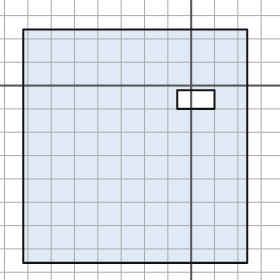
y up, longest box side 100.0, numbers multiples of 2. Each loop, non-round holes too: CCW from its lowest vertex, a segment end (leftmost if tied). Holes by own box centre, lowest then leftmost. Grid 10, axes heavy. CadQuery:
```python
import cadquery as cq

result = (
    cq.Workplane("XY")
    .moveTo(-72.0, -76.0)
    .lineTo(24.0, -76.0)
    .lineTo(24.0, 24.0)
    .lineTo(-72.0, 24.0)
    .close()
    .moveTo(-6.0, -10.0)
    .lineTo(10.0, -10.0)
    .lineTo(10.0, -2.0)
    .lineTo(-6.0, -2.0)
    .close()
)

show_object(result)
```